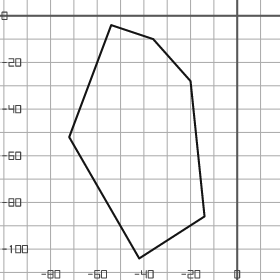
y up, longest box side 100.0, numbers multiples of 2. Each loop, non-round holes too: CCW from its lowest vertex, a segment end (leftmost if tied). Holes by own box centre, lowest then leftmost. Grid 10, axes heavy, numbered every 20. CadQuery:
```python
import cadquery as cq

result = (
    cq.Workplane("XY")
    .moveTo(-42.0, -104.0)
    .lineTo(-14.0, -86.0)
    .lineTo(-20.0, -28.0)
    .lineTo(-36.0, -10.0)
    .lineTo(-54.0, -4.0)
    .lineTo(-72.0, -52.0)
    .close()
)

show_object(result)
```